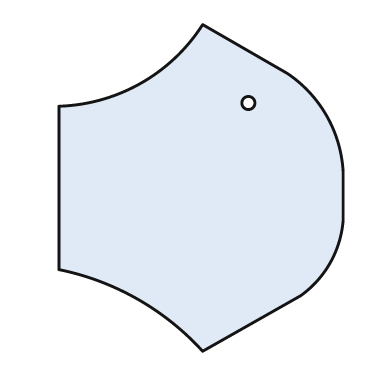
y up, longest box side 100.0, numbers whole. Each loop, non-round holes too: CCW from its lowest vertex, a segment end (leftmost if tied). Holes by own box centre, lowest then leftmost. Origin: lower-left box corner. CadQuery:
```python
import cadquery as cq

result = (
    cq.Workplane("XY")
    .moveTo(44.0, 0.0)
    .lineTo(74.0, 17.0)
    .threePointArc((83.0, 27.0), (87.0, 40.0))
    .lineTo(87.0, 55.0)
    .threePointArc((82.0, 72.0), (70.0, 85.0))
    .lineTo(44.0, 100.0)
    .threePointArc((25.0, 82.0), (0.0, 75.0))
    .lineTo(0.0, 25.0)
    .threePointArc((24.0, 16.0), (44.0, 0.0))
    .close()
    .moveTo(58.0, 76.0)
    .circle(2.0)
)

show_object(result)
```